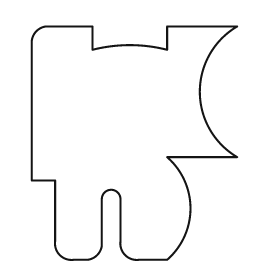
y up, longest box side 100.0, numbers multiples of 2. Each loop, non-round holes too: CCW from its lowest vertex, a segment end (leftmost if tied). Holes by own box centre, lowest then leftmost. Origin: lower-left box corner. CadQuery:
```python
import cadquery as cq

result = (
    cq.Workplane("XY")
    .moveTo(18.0, 0.0)
    .lineTo(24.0, 0.0)
    .threePointArc((28.0, 2.0), (30.0, 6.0))
    .lineTo(30.0, 26.0)
    .threePointArc((34.0, 30.0), (38.0, 26.0))
    .lineTo(38.0, 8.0)
    .threePointArc((40.0, 2.0), (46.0, 0.0))
    .lineTo(58.0, 0.0)
    .threePointArc((68.0, 22.0), (58.0, 44.0))
    .lineTo(88.0, 44.0)
    .threePointArc((72.0, 72.0), (88.0, 100.0))
    .lineTo(58.0, 100.0)
    .lineTo(58.0, 90.0)
    .threePointArc((42.0, 92.0), (26.0, 90.0))
    .lineTo(26.0, 100.0)
    .lineTo(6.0, 100.0)
    .threePointArc((2.0, 98.0), (0.0, 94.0))
    .lineTo(0.0, 34.0)
    .lineTo(10.0, 34.0)
    .lineTo(10.0, 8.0)
    .threePointArc((12.0, 2.0), (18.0, 0.0))
    .close()
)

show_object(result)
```